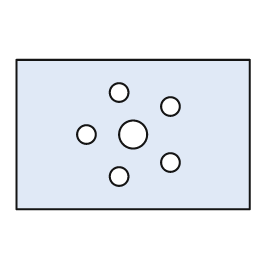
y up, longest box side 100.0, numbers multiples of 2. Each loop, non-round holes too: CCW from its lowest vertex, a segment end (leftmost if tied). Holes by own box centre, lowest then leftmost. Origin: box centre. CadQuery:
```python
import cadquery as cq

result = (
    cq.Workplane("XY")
    .moveTo(-50.0, -32.0)
    .lineTo(50.0, -32.0)
    .lineTo(50.0, 32.0)
    .lineTo(-50.0, 32.0)
    .close()
    .moveTo(-6.0, -18.0)
    .circle(4.0)
    .moveTo(16.0, -12.0)
    .circle(4.0)
    .moveTo(-20.0, 0.0)
    .circle(4.0)
    .moveTo(0.0, 0.0)
    .circle(6.0)
    .moveTo(16.0, 12.0)
    .circle(4.0)
    .moveTo(-6.0, 18.0)
    .circle(4.0)
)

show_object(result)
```